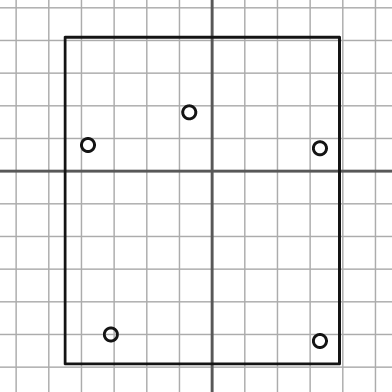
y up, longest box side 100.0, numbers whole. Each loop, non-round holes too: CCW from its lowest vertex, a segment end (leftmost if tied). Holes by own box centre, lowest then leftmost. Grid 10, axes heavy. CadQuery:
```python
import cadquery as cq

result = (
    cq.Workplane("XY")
    .moveTo(-45.0, -59.0)
    .lineTo(39.0, -59.0)
    .lineTo(39.0, 41.0)
    .lineTo(-45.0, 41.0)
    .close()
    .moveTo(33.0, -52.0)
    .circle(2.0)
    .moveTo(-31.0, -50.0)
    .circle(2.0)
    .moveTo(33.0, 7.0)
    .circle(2.0)
    .moveTo(-38.0, 8.0)
    .circle(2.0)
    .moveTo(-7.0, 18.0)
    .circle(2.0)
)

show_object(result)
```